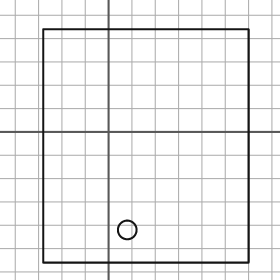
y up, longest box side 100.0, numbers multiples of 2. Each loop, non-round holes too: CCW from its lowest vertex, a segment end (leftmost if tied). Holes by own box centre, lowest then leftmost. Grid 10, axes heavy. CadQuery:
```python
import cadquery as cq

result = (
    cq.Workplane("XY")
    .moveTo(-28.0, -56.0)
    .lineTo(60.0, -56.0)
    .lineTo(60.0, 44.0)
    .lineTo(-28.0, 44.0)
    .close()
    .moveTo(8.0, -42.0)
    .circle(4.0)
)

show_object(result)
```